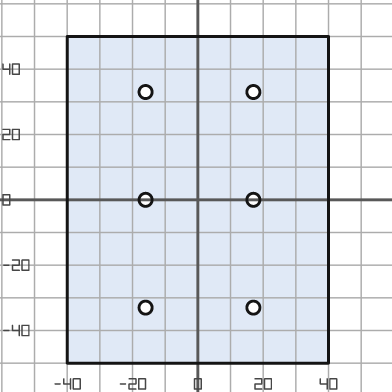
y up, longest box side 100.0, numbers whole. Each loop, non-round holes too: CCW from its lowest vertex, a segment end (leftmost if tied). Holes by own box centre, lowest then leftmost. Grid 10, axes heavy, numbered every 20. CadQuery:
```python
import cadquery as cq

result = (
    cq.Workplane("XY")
    .moveTo(-40.0, -50.0)
    .lineTo(40.0, -50.0)
    .lineTo(40.0, 50.0)
    .lineTo(-40.0, 50.0)
    .close()
    .moveTo(-16.0, -33.0)
    .circle(2.0)
    .moveTo(17.0, -33.0)
    .circle(2.0)
    .moveTo(-16.0, 0.0)
    .circle(2.0)
    .moveTo(17.0, 0.0)
    .circle(2.0)
    .moveTo(-16.0, 33.0)
    .circle(2.0)
    .moveTo(17.0, 33.0)
    .circle(2.0)
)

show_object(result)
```